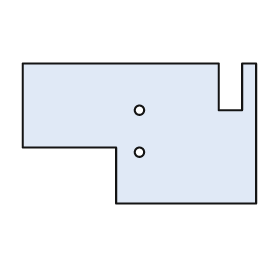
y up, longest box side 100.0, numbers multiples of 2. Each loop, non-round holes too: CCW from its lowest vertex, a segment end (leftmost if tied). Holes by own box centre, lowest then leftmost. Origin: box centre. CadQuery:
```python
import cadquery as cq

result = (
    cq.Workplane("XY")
    .moveTo(-10.0, -30.0)
    .lineTo(50.0, -30.0)
    .lineTo(50.0, 30.0)
    .lineTo(44.0, 30.0)
    .lineTo(44.0, 10.0)
    .lineTo(34.0, 10.0)
    .lineTo(34.0, 30.0)
    .lineTo(-50.0, 30.0)
    .lineTo(-50.0, -6.0)
    .lineTo(-10.0, -6.0)
    .close()
    .moveTo(0.0, -8.0)
    .circle(2.0)
    .moveTo(0.0, 10.0)
    .circle(2.0)
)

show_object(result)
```